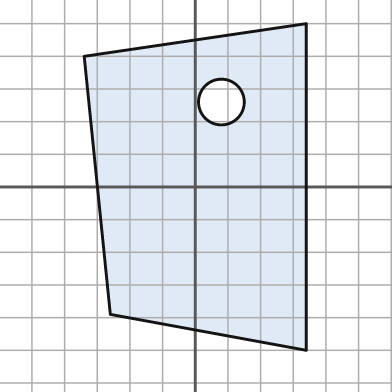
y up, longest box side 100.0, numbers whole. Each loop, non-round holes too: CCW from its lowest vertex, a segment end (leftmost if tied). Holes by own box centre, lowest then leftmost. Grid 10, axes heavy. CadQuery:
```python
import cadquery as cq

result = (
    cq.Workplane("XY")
    .moveTo(34.0, -50.0)
    .lineTo(34.0, 50.0)
    .lineTo(-34.0, 40.0)
    .lineTo(-26.0, -39.0)
    .close()
    .moveTo(8.0, 26.0)
    .circle(7.0)
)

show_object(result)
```